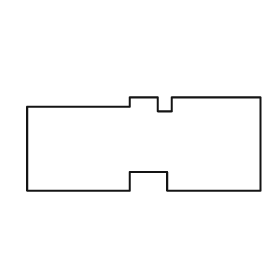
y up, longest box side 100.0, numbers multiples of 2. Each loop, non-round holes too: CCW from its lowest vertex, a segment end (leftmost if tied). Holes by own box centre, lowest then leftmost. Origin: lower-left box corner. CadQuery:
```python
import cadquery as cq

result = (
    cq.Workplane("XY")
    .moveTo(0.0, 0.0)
    .lineTo(44.0, 0.0)
    .lineTo(44.0, 8.0)
    .lineTo(60.0, 8.0)
    .lineTo(60.0, 0.0)
    .lineTo(100.0, 0.0)
    .lineTo(100.0, 40.0)
    .lineTo(62.0, 40.0)
    .lineTo(62.0, 34.0)
    .lineTo(56.0, 34.0)
    .lineTo(56.0, 40.0)
    .lineTo(44.0, 40.0)
    .lineTo(44.0, 36.0)
    .lineTo(0.0, 36.0)
    .close()
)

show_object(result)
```